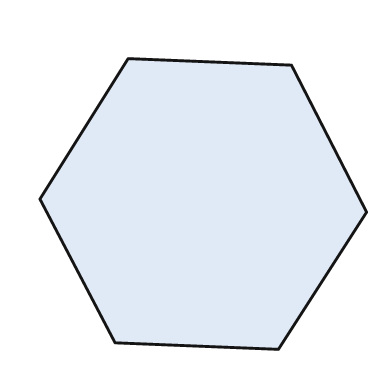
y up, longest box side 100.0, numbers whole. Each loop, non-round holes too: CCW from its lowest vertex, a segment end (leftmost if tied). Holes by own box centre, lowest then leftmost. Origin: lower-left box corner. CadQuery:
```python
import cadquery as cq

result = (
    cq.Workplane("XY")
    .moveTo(73.0, 0.0)
    .lineTo(100.0, 42.0)
    .lineTo(77.0, 87.0)
    .lineTo(27.0, 89.0)
    .lineTo(0.0, 46.0)
    .lineTo(23.0, 2.0)
    .close()
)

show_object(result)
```